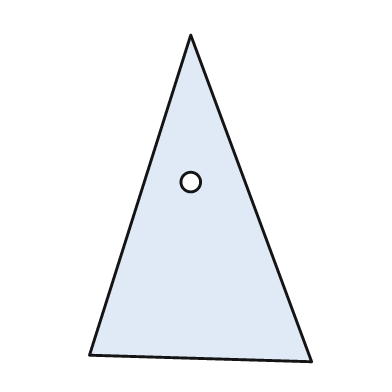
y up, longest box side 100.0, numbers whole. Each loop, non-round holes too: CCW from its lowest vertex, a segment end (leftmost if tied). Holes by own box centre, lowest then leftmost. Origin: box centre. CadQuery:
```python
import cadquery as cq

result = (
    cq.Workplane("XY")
    .moveTo(34.0, -50.0)
    .lineTo(-3.0, 50.0)
    .lineTo(-34.0, -48.0)
    .close()
    .moveTo(-3.0, 5.0)
    .circle(3.0)
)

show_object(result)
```